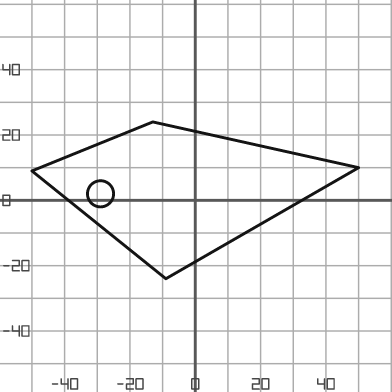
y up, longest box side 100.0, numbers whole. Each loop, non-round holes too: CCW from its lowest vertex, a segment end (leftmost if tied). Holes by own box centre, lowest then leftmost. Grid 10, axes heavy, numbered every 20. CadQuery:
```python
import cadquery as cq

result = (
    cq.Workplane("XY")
    .moveTo(-9.0, -24.0)
    .lineTo(50.0, 10.0)
    .lineTo(-13.0, 24.0)
    .lineTo(-50.0, 9.0)
    .close()
    .moveTo(-29.0, 2.0)
    .circle(4.0)
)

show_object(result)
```